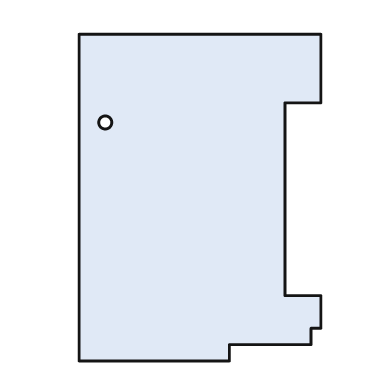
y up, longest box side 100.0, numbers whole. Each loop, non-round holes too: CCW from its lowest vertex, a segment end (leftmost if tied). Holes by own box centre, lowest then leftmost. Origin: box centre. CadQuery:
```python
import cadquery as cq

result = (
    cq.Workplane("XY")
    .moveTo(-37.0, -50.0)
    .lineTo(9.0, -50.0)
    .lineTo(9.0, -45.0)
    .lineTo(34.0, -45.0)
    .lineTo(34.0, -40.0)
    .lineTo(37.0, -40.0)
    .lineTo(37.0, -30.0)
    .lineTo(26.0, -30.0)
    .lineTo(26.0, 29.0)
    .lineTo(37.0, 29.0)
    .lineTo(37.0, 50.0)
    .lineTo(-37.0, 50.0)
    .close()
    .moveTo(-29.0, 23.0)
    .circle(2.0)
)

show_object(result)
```